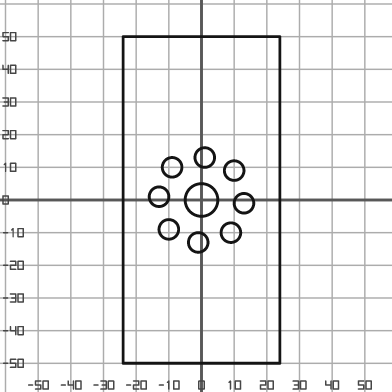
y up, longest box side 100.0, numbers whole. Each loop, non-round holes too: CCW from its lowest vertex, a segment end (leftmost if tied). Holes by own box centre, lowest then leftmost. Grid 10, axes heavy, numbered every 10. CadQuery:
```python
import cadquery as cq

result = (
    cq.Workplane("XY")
    .moveTo(-24.0, -50.0)
    .lineTo(24.0, -50.0)
    .lineTo(24.0, 50.0)
    .lineTo(-24.0, 50.0)
    .close()
    .moveTo(-1.0, -13.0)
    .circle(3.0)
    .moveTo(9.0, -10.0)
    .circle(3.0)
    .moveTo(-10.0, -9.0)
    .circle(3.0)
    .moveTo(13.0, -1.0)
    .circle(3.0)
    .moveTo(0.0, 0.0)
    .circle(5.0)
    .moveTo(-13.0, 1.0)
    .circle(3.0)
    .moveTo(10.0, 9.0)
    .circle(3.0)
    .moveTo(-9.0, 10.0)
    .circle(3.0)
    .moveTo(1.0, 13.0)
    .circle(3.0)
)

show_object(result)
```